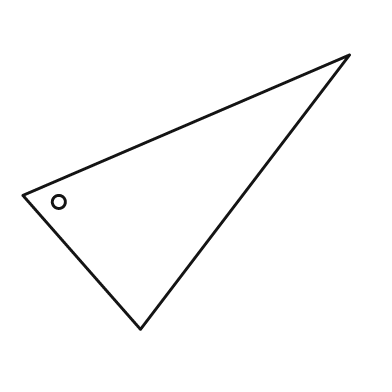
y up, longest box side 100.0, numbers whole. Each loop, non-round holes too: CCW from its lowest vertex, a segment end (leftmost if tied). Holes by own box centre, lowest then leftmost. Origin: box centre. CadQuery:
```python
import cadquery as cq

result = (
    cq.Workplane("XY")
    .moveTo(-14.0, -42.0)
    .lineTo(50.0, 42.0)
    .lineTo(-50.0, -1.0)
    .close()
    .moveTo(-39.0, -3.0)
    .circle(2.0)
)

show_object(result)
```